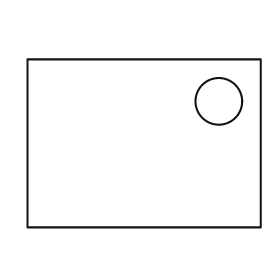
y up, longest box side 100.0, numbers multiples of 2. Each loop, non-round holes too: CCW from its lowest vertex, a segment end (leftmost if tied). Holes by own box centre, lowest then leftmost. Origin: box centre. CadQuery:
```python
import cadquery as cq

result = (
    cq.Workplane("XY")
    .moveTo(-50.0, -36.0)
    .lineTo(50.0, -36.0)
    .lineTo(50.0, 36.0)
    .lineTo(-50.0, 36.0)
    .close()
    .moveTo(32.0, 18.0)
    .circle(10.0)
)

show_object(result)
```